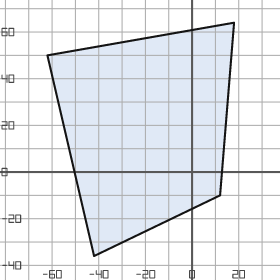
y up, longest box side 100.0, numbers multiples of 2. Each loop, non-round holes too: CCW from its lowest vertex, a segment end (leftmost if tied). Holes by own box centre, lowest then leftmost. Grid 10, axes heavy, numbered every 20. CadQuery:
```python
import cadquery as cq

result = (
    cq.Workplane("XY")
    .moveTo(-42.0, -36.0)
    .lineTo(12.0, -10.0)
    .lineTo(18.0, 64.0)
    .lineTo(-62.0, 50.0)
    .close()
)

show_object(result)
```